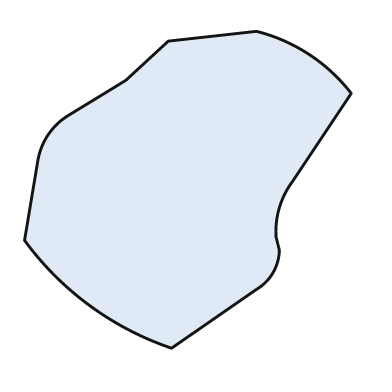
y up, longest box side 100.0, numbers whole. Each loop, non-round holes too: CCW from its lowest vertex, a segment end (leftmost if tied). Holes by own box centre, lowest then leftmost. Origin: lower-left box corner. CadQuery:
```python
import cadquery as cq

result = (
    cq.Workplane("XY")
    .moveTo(45.0, 0.0)
    .lineTo(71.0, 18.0)
    .threePointArc((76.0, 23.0), (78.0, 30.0))
    .lineTo(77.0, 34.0)
    .threePointArc((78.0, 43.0), (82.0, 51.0))
    .lineTo(100.0, 78.0)
    .threePointArc((87.0, 90.0), (71.0, 97.0))
    .lineTo(44.0, 94.0)
    .lineTo(31.0, 82.0)
    .lineTo(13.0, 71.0)
    .threePointArc((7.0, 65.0), (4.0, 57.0))
    .lineTo(0.0, 33.0)
    .threePointArc((20.0, 13.0), (45.0, 0.0))
    .close()
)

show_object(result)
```